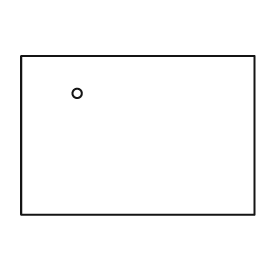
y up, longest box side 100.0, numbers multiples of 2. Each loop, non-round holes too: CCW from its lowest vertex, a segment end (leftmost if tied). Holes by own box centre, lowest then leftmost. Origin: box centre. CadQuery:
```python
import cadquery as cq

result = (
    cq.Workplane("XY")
    .moveTo(-50.0, -34.0)
    .lineTo(50.0, -34.0)
    .lineTo(50.0, 34.0)
    .lineTo(-50.0, 34.0)
    .close()
    .moveTo(-26.0, 18.0)
    .circle(2.0)
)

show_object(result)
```